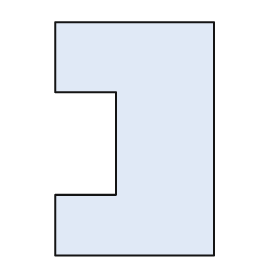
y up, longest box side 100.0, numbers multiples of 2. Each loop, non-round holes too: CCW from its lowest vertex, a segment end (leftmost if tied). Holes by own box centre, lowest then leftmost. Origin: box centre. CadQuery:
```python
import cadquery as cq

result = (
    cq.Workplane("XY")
    .moveTo(-34.0, -50.0)
    .lineTo(34.0, -50.0)
    .lineTo(34.0, 50.0)
    .lineTo(-34.0, 50.0)
    .lineTo(-34.0, 20.0)
    .lineTo(-8.0, 20.0)
    .lineTo(-8.0, -24.0)
    .lineTo(-34.0, -24.0)
    .close()
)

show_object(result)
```